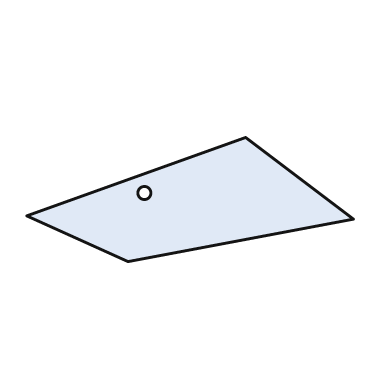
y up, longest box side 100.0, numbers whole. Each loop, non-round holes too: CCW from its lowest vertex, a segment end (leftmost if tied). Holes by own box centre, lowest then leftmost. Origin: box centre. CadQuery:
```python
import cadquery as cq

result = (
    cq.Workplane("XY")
    .moveTo(-19.0, -19.0)
    .lineTo(50.0, -6.0)
    .lineTo(17.0, 19.0)
    .lineTo(-50.0, -5.0)
    .close()
    .moveTo(-14.0, 2.0)
    .circle(2.0)
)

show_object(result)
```